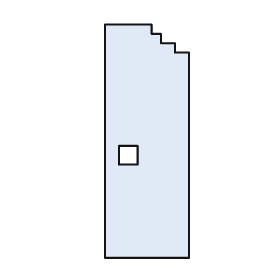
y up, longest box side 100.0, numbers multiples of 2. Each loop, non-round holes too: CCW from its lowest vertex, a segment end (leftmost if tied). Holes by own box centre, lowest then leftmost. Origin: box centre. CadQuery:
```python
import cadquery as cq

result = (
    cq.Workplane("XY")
    .moveTo(-18.0, -50.0)
    .lineTo(18.0, -50.0)
    .lineTo(18.0, 38.0)
    .lineTo(12.0, 38.0)
    .lineTo(12.0, 42.0)
    .lineTo(6.0, 42.0)
    .lineTo(6.0, 46.0)
    .lineTo(2.0, 46.0)
    .lineTo(2.0, 50.0)
    .lineTo(-18.0, 50.0)
    .close()
    .moveTo(-12.0, -10.0)
    .lineTo(-4.0, -10.0)
    .lineTo(-4.0, -2.0)
    .lineTo(-12.0, -2.0)
    .close()
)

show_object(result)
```